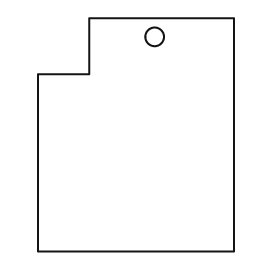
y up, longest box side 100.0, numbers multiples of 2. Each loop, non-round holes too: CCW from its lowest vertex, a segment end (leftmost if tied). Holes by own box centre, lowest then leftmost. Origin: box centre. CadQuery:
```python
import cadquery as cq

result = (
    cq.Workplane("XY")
    .moveTo(-42.0, -50.0)
    .lineTo(42.0, -50.0)
    .lineTo(42.0, 50.0)
    .lineTo(-20.0, 50.0)
    .lineTo(-20.0, 26.0)
    .lineTo(-42.0, 26.0)
    .close()
    .moveTo(8.0, 42.0)
    .circle(4.0)
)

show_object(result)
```